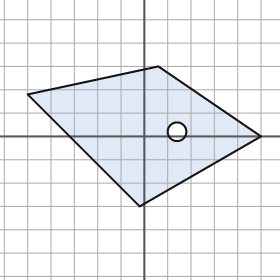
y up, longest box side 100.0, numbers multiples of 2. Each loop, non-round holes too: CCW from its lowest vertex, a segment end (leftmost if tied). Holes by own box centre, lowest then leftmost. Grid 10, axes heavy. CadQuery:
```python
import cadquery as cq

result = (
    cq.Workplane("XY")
    .moveTo(-2.0, -30.0)
    .lineTo(50.0, 0.0)
    .lineTo(6.0, 30.0)
    .lineTo(-50.0, 18.0)
    .close()
    .moveTo(14.0, 2.0)
    .circle(4.0)
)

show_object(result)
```